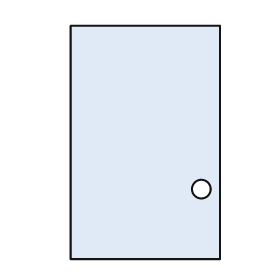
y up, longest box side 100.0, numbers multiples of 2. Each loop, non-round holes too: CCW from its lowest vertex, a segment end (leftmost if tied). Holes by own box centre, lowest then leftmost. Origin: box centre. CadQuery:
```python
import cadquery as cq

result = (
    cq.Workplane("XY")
    .moveTo(-32.0, -50.0)
    .lineTo(32.0, -50.0)
    .lineTo(32.0, 50.0)
    .lineTo(-32.0, 50.0)
    .close()
    .moveTo(24.0, -20.0)
    .circle(4.0)
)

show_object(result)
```